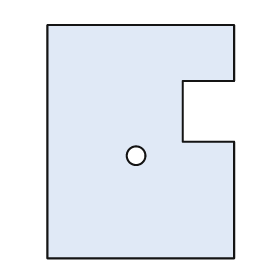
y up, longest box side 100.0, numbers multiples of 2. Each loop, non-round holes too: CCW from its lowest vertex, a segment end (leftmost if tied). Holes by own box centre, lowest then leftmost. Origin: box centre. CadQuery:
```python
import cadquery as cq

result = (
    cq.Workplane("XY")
    .moveTo(-40.0, -50.0)
    .lineTo(40.0, -50.0)
    .lineTo(40.0, 0.0)
    .lineTo(18.0, 0.0)
    .lineTo(18.0, 26.0)
    .lineTo(40.0, 26.0)
    .lineTo(40.0, 50.0)
    .lineTo(-40.0, 50.0)
    .close()
    .moveTo(-2.0, -6.0)
    .circle(4.0)
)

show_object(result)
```